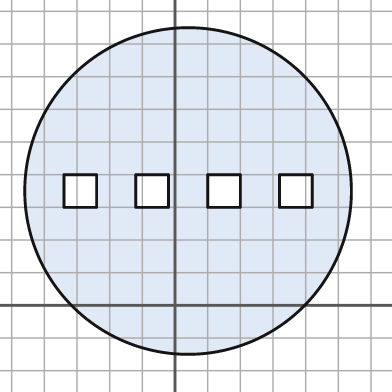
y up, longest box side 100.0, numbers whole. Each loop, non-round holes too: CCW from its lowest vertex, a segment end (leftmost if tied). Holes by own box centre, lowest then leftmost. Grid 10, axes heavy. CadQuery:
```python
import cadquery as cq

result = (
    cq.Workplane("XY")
    .moveTo(4.0, 35.0)
    .circle(50.0)
    .moveTo(-34.0, 30.0)
    .lineTo(-24.0, 30.0)
    .lineTo(-24.0, 40.0)
    .lineTo(-34.0, 40.0)
    .close()
    .moveTo(-12.0, 30.0)
    .lineTo(-2.0, 30.0)
    .lineTo(-2.0, 40.0)
    .lineTo(-12.0, 40.0)
    .close()
    .moveTo(10.0, 30.0)
    .lineTo(20.0, 30.0)
    .lineTo(20.0, 40.0)
    .lineTo(10.0, 40.0)
    .close()
    .moveTo(32.0, 30.0)
    .lineTo(42.0, 30.0)
    .lineTo(42.0, 40.0)
    .lineTo(32.0, 40.0)
    .close()
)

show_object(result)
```